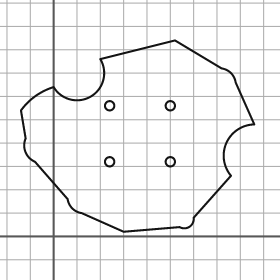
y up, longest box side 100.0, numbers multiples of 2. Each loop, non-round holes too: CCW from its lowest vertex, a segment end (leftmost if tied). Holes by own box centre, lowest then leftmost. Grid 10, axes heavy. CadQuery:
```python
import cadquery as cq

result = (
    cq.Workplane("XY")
    .moveTo(30.0, 2.0)
    .lineTo(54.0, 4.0)
    .threePointArc((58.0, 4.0), (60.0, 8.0))
    .lineTo(76.0, 26.0)
    .threePointArc((74.0, 40.0), (86.0, 48.0))
    .lineTo(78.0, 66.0)
    .threePointArc((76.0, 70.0), (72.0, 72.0))
    .lineTo(52.0, 84.0)
    .lineTo(20.0, 76.0)
    .threePointArc((16.0, 60.0), (0.0, 64.0))
    .threePointArc((-8.0, 60.0), (-14.0, 54.0))
    .lineTo(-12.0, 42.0)
    .threePointArc((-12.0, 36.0), (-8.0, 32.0))
    .lineTo(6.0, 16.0)
    .threePointArc((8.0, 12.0), (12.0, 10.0))
    .close()
    .moveTo(24.0, 32.0)
    .circle(2.0)
    .moveTo(50.0, 32.0)
    .circle(2.0)
    .moveTo(24.0, 56.0)
    .circle(2.0)
    .moveTo(50.0, 56.0)
    .circle(2.0)
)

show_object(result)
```